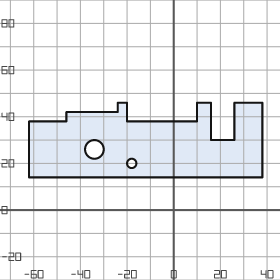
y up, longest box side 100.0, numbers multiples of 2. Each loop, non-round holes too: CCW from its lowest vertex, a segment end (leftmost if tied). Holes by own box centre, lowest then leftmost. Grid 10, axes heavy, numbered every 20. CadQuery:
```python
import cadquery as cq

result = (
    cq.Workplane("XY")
    .moveTo(-62.0, 14.0)
    .lineTo(38.0, 14.0)
    .lineTo(38.0, 46.0)
    .lineTo(26.0, 46.0)
    .lineTo(26.0, 30.0)
    .lineTo(16.0, 30.0)
    .lineTo(16.0, 46.0)
    .lineTo(10.0, 46.0)
    .lineTo(10.0, 38.0)
    .lineTo(-20.0, 38.0)
    .lineTo(-20.0, 46.0)
    .lineTo(-24.0, 46.0)
    .lineTo(-24.0, 42.0)
    .lineTo(-46.0, 42.0)
    .lineTo(-46.0, 38.0)
    .lineTo(-62.0, 38.0)
    .close()
    .moveTo(-18.0, 20.0)
    .circle(2.0)
    .moveTo(-34.0, 26.0)
    .circle(4.0)
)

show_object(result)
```